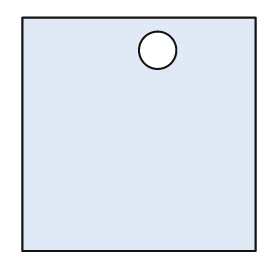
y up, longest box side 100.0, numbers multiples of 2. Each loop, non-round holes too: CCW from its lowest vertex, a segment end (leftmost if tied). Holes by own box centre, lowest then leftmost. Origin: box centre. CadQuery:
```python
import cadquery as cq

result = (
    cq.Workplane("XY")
    .moveTo(-50.0, -50.0)
    .lineTo(50.0, -50.0)
    .lineTo(50.0, 50.0)
    .lineTo(-50.0, 50.0)
    .close()
    .moveTo(8.0, 36.0)
    .circle(8.0)
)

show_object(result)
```